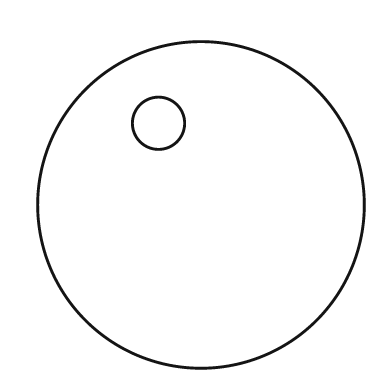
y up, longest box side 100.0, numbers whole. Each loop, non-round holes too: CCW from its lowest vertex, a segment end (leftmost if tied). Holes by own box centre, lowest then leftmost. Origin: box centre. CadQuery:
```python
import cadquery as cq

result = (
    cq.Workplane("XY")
    .moveTo(0.0, 0.0)
    .circle(50.0)
    .moveTo(-13.0, 25.0)
    .circle(8.0)
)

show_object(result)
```